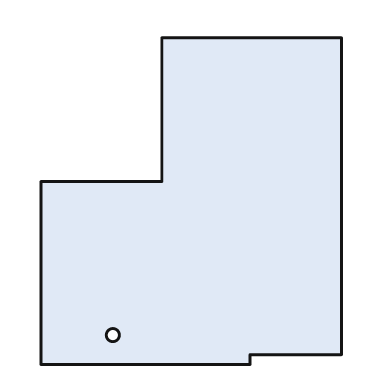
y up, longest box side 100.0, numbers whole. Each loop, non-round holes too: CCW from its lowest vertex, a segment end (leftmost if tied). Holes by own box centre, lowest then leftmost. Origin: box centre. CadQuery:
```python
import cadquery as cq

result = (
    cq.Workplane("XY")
    .moveTo(-46.0, -50.0)
    .lineTo(18.0, -50.0)
    .lineTo(18.0, -47.0)
    .lineTo(46.0, -47.0)
    .lineTo(46.0, 50.0)
    .lineTo(-9.0, 50.0)
    .lineTo(-9.0, 6.0)
    .lineTo(-46.0, 6.0)
    .close()
    .moveTo(-24.0, -41.0)
    .circle(2.0)
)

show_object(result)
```